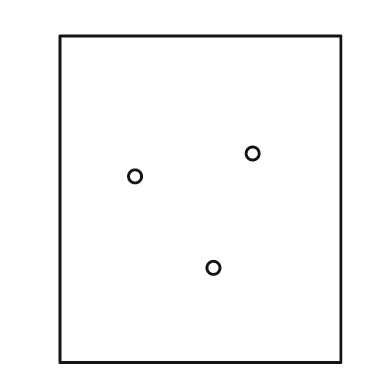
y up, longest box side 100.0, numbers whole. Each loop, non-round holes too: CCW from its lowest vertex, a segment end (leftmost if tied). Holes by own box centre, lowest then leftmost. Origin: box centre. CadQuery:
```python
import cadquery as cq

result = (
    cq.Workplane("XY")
    .moveTo(-43.0, -50.0)
    .lineTo(43.0, -50.0)
    .lineTo(43.0, 50.0)
    .lineTo(-43.0, 50.0)
    .close()
    .moveTo(4.0, -21.0)
    .circle(2.0)
    .moveTo(-20.0, 7.0)
    .circle(2.0)
    .moveTo(16.0, 14.0)
    .circle(2.0)
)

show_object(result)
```